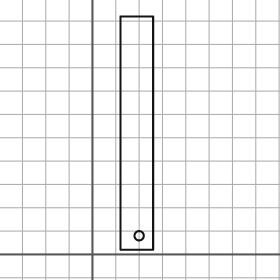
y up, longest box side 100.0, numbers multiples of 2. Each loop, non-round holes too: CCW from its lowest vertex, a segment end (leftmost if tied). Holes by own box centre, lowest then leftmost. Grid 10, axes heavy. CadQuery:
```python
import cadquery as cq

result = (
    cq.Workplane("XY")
    .moveTo(12.0, 2.0)
    .lineTo(26.0, 2.0)
    .lineTo(26.0, 102.0)
    .lineTo(12.0, 102.0)
    .close()
    .moveTo(20.0, 8.0)
    .circle(2.0)
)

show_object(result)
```